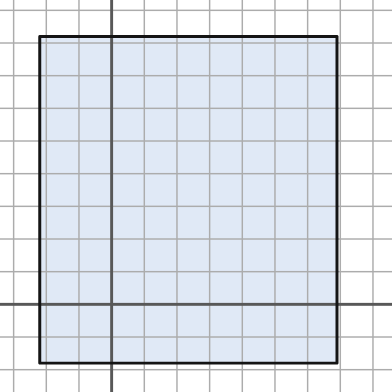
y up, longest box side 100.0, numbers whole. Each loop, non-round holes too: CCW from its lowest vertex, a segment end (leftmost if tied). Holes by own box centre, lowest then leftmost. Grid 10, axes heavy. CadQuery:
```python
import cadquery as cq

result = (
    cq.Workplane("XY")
    .moveTo(-22.0, -18.0)
    .lineTo(69.0, -18.0)
    .lineTo(69.0, 82.0)
    .lineTo(-22.0, 82.0)
    .close()
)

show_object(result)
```